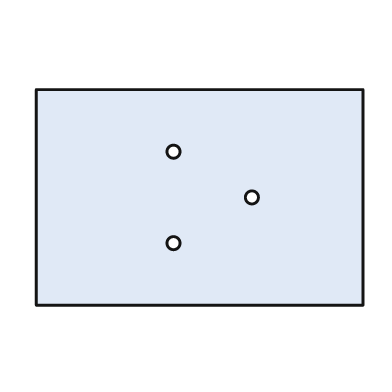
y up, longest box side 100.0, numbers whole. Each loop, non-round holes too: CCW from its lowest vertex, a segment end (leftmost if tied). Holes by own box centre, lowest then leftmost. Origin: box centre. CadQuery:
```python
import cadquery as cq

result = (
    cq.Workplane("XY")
    .moveTo(-50.0, -33.0)
    .lineTo(50.0, -33.0)
    .lineTo(50.0, 33.0)
    .lineTo(-50.0, 33.0)
    .close()
    .moveTo(-8.0, -14.0)
    .circle(2.0)
    .moveTo(16.0, 0.0)
    .circle(2.0)
    .moveTo(-8.0, 14.0)
    .circle(2.0)
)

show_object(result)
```